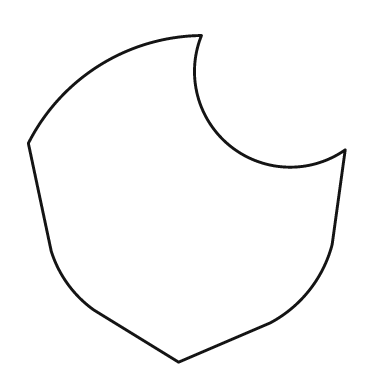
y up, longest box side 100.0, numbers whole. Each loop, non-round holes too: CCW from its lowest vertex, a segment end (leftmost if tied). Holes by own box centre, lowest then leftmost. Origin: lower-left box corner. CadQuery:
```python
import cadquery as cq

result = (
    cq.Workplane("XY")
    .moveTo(46.0, 0.0)
    .lineTo(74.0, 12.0)
    .threePointArc((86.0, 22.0), (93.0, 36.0))
    .lineTo(97.0, 65.0)
    .threePointArc((62.0, 66.0), (53.0, 100.0))
    .threePointArc((22.0, 91.0), (0.0, 67.0))
    .lineTo(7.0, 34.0)
    .threePointArc((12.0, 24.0), (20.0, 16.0))
    .close()
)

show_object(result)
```